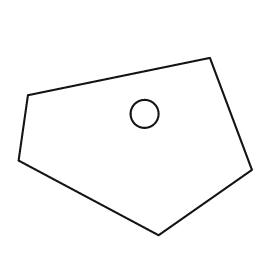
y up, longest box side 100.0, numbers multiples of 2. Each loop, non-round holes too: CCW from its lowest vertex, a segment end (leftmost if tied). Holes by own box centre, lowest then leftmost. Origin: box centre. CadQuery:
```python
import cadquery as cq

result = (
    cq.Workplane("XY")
    .moveTo(10.0, -38.0)
    .lineTo(50.0, -10.0)
    .lineTo(32.0, 38.0)
    .lineTo(-46.0, 22.0)
    .lineTo(-50.0, -6.0)
    .close()
    .moveTo(4.0, 14.0)
    .circle(6.0)
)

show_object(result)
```